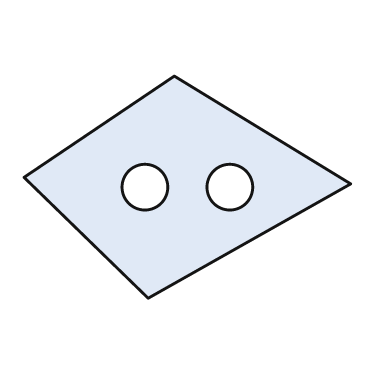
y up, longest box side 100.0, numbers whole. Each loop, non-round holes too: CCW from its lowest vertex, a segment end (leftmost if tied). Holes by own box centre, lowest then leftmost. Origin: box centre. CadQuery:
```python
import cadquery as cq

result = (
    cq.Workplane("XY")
    .moveTo(-12.0, -34.0)
    .lineTo(50.0, 1.0)
    .lineTo(-4.0, 34.0)
    .lineTo(-50.0, 3.0)
    .close()
    .moveTo(-13.0, 0.0)
    .circle(7.0)
    .moveTo(13.0, 0.0)
    .circle(7.0)
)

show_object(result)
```